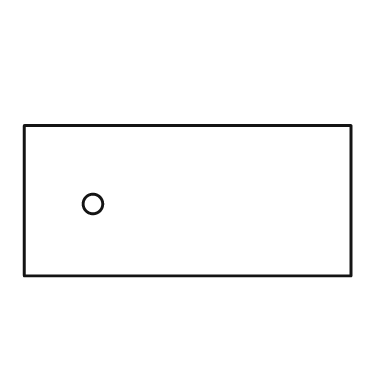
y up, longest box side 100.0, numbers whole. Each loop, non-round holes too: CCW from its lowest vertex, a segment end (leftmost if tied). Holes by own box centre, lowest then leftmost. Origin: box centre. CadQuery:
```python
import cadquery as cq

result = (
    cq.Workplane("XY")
    .moveTo(-50.0, -23.0)
    .lineTo(50.0, -23.0)
    .lineTo(50.0, 23.0)
    .lineTo(-50.0, 23.0)
    .close()
    .moveTo(-29.0, -1.0)
    .circle(3.0)
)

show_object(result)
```